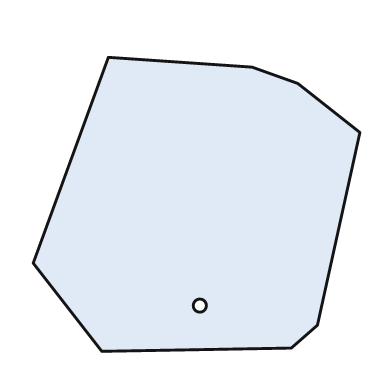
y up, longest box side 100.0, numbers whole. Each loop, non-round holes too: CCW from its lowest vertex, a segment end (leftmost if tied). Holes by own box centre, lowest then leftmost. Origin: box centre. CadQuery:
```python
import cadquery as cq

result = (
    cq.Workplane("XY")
    .moveTo(-29.0, -45.0)
    .lineTo(29.0, -44.0)
    .lineTo(37.0, -37.0)
    .lineTo(50.0, 22.0)
    .lineTo(31.0, 37.0)
    .lineTo(17.0, 42.0)
    .lineTo(-27.0, 45.0)
    .lineTo(-50.0, -18.0)
    .close()
    .moveTo(1.0, -31.0)
    .circle(2.0)
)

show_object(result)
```